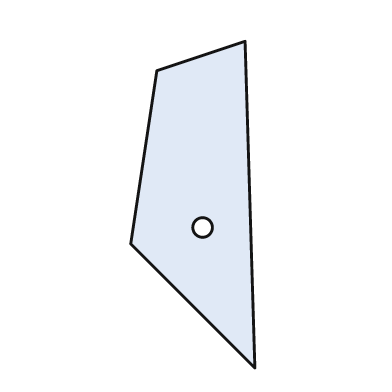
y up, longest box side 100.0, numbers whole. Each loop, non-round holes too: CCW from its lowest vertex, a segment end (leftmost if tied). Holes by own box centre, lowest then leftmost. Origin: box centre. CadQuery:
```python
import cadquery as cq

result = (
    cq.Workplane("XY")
    .moveTo(19.0, -50.0)
    .lineTo(16.0, 50.0)
    .lineTo(-11.0, 41.0)
    .lineTo(-19.0, -12.0)
    .close()
    .moveTo(3.0, -7.0)
    .circle(3.0)
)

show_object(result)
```